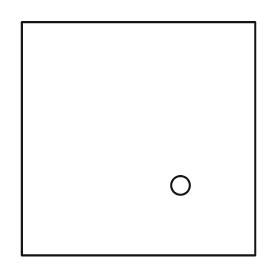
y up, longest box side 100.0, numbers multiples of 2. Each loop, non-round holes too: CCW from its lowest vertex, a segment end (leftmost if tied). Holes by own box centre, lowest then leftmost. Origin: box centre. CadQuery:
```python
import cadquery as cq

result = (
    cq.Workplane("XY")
    .moveTo(-50.0, -50.0)
    .lineTo(50.0, -50.0)
    .lineTo(50.0, 50.0)
    .lineTo(-50.0, 50.0)
    .close()
    .moveTo(18.0, -20.0)
    .circle(4.0)
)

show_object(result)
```